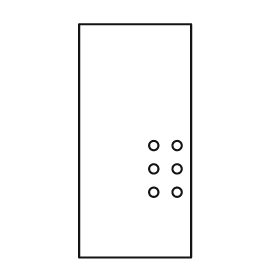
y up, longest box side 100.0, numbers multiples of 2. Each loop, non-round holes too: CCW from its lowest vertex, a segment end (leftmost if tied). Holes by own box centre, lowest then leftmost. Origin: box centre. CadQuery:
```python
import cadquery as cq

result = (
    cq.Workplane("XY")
    .moveTo(-24.0, -50.0)
    .lineTo(24.0, -50.0)
    .lineTo(24.0, 50.0)
    .lineTo(-24.0, 50.0)
    .close()
    .moveTo(8.0, -22.0)
    .circle(2.0)
    .moveTo(18.0, -22.0)
    .circle(2.0)
    .moveTo(8.0, -12.0)
    .circle(2.0)
    .moveTo(18.0, -12.0)
    .circle(2.0)
    .moveTo(8.0, -2.0)
    .circle(2.0)
    .moveTo(18.0, -2.0)
    .circle(2.0)
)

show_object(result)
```